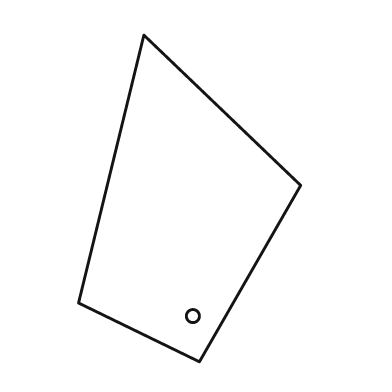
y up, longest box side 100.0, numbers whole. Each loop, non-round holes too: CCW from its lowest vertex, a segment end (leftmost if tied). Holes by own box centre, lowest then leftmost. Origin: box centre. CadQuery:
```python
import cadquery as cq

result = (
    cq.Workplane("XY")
    .moveTo(3.0, -50.0)
    .lineTo(34.0, 4.0)
    .lineTo(-14.0, 50.0)
    .lineTo(-34.0, -32.0)
    .close()
    .moveTo(1.0, -36.0)
    .circle(2.0)
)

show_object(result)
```